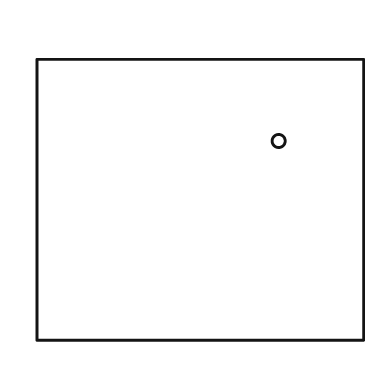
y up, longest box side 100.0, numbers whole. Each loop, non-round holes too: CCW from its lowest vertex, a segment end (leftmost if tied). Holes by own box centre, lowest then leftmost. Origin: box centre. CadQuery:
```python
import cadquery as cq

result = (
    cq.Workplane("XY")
    .moveTo(-50.0, -43.0)
    .lineTo(50.0, -43.0)
    .lineTo(50.0, 43.0)
    .lineTo(-50.0, 43.0)
    .close()
    .moveTo(24.0, 18.0)
    .circle(2.0)
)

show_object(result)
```